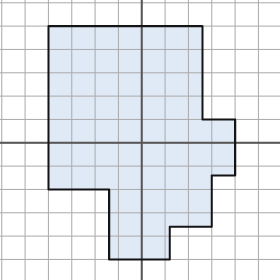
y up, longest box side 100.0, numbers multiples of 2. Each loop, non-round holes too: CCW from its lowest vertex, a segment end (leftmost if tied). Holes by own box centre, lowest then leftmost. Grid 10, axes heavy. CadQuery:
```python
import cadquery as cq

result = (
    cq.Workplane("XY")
    .moveTo(-14.0, -50.0)
    .lineTo(12.0, -50.0)
    .lineTo(12.0, -36.0)
    .lineTo(30.0, -36.0)
    .lineTo(30.0, -14.0)
    .lineTo(40.0, -14.0)
    .lineTo(40.0, 10.0)
    .lineTo(26.0, 10.0)
    .lineTo(26.0, 50.0)
    .lineTo(-40.0, 50.0)
    .lineTo(-40.0, -20.0)
    .lineTo(-14.0, -20.0)
    .close()
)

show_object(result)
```